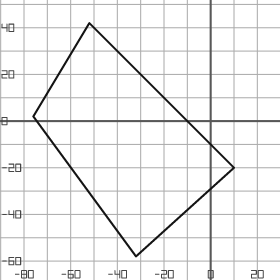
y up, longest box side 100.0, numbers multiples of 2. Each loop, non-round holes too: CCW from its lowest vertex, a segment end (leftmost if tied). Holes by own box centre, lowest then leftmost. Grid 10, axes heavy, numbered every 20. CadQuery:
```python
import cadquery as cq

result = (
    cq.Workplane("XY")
    .moveTo(-32.0, -58.0)
    .lineTo(10.0, -20.0)
    .lineTo(-52.0, 42.0)
    .lineTo(-76.0, 2.0)
    .close()
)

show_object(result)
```